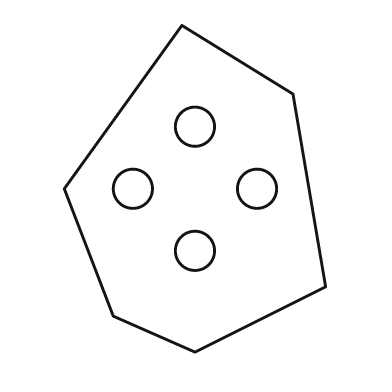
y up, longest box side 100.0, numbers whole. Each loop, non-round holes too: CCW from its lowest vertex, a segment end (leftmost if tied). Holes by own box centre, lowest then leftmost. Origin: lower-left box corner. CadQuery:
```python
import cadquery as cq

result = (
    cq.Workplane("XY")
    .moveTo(40.0, 0.0)
    .lineTo(80.0, 20.0)
    .lineTo(70.0, 79.0)
    .lineTo(36.0, 100.0)
    .lineTo(0.0, 50.0)
    .lineTo(15.0, 11.0)
    .close()
    .moveTo(40.0, 31.0)
    .circle(6.0)
    .moveTo(21.0, 50.0)
    .circle(6.0)
    .moveTo(59.0, 50.0)
    .circle(6.0)
    .moveTo(40.0, 69.0)
    .circle(6.0)
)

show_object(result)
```